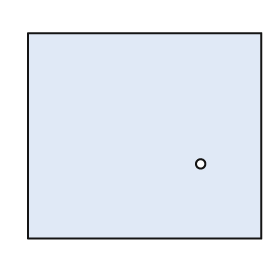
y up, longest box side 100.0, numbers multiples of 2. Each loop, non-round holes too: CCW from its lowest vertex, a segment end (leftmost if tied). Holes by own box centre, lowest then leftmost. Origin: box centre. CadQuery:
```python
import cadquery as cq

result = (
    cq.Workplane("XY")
    .moveTo(-50.0, -44.0)
    .lineTo(50.0, -44.0)
    .lineTo(50.0, 44.0)
    .lineTo(-50.0, 44.0)
    .close()
    .moveTo(24.0, -12.0)
    .circle(2.0)
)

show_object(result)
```